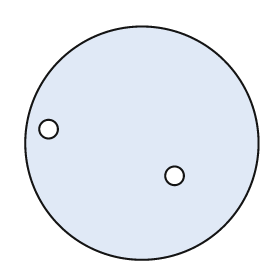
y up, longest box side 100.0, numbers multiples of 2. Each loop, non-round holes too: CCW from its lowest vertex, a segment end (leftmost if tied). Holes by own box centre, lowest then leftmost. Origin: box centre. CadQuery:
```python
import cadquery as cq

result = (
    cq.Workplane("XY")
    .moveTo(0.0, 0.0)
    .circle(50.0)
    .moveTo(14.0, -14.0)
    .circle(4.0)
    .moveTo(-40.0, 6.0)
    .circle(4.0)
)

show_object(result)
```